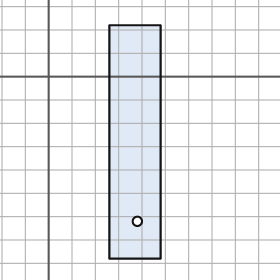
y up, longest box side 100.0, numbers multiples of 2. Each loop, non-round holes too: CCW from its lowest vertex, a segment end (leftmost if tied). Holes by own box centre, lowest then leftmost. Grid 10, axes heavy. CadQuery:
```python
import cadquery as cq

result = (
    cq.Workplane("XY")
    .moveTo(26.0, -78.0)
    .lineTo(48.0, -78.0)
    .lineTo(48.0, 22.0)
    .lineTo(26.0, 22.0)
    .close()
    .moveTo(38.0, -62.0)
    .circle(2.0)
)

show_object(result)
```